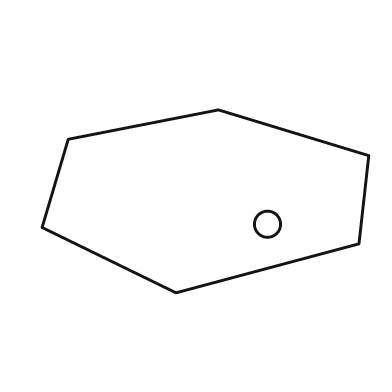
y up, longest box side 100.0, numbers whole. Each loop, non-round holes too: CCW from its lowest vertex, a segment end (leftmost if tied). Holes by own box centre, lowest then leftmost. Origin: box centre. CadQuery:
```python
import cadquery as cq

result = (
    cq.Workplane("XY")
    .moveTo(-9.0, -28.0)
    .lineTo(47.0, -13.0)
    .lineTo(50.0, 14.0)
    .lineTo(4.0, 28.0)
    .lineTo(-42.0, 19.0)
    .lineTo(-50.0, -8.0)
    .close()
    .moveTo(19.0, -7.0)
    .circle(4.0)
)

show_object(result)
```